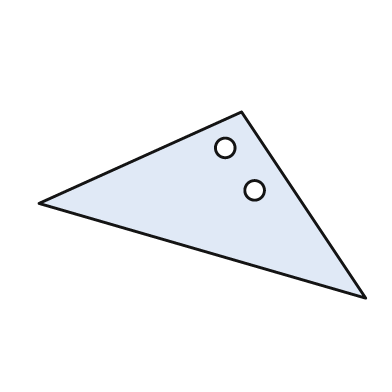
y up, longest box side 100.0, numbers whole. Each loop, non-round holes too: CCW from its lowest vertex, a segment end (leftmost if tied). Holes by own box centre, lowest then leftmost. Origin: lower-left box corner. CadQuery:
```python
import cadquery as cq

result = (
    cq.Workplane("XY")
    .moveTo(100.0, 0.0)
    .lineTo(62.0, 57.0)
    .lineTo(0.0, 29.0)
    .close()
    .moveTo(66.0, 33.0)
    .circle(3.0)
    .moveTo(57.0, 46.0)
    .circle(3.0)
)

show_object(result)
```